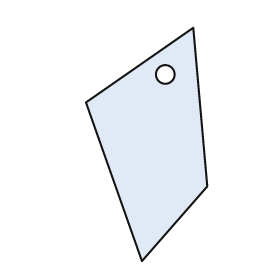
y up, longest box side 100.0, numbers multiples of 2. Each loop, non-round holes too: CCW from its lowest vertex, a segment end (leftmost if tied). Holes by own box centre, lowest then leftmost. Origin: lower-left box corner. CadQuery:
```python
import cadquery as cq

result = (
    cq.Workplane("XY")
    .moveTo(24.0, 0.0)
    .lineTo(52.0, 32.0)
    .lineTo(46.0, 100.0)
    .lineTo(0.0, 68.0)
    .close()
    .moveTo(34.0, 80.0)
    .circle(4.0)
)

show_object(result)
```